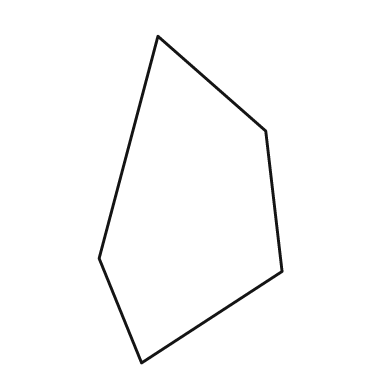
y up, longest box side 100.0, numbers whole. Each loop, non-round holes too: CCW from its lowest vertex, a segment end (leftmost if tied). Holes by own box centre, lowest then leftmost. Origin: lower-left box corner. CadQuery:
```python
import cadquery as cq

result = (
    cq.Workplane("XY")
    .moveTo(13.0, 0.0)
    .lineTo(56.0, 28.0)
    .lineTo(51.0, 71.0)
    .lineTo(18.0, 100.0)
    .lineTo(0.0, 32.0)
    .close()
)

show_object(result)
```